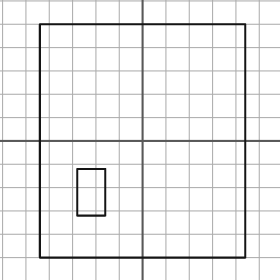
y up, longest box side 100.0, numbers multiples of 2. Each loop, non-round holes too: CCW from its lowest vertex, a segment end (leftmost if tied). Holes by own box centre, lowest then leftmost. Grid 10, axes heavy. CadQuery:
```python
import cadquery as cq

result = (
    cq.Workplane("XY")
    .moveTo(-44.0, -50.0)
    .lineTo(44.0, -50.0)
    .lineTo(44.0, 50.0)
    .lineTo(-44.0, 50.0)
    .close()
    .moveTo(-28.0, -32.0)
    .lineTo(-16.0, -32.0)
    .lineTo(-16.0, -12.0)
    .lineTo(-28.0, -12.0)
    .close()
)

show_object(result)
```